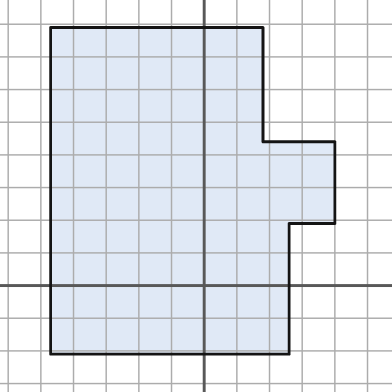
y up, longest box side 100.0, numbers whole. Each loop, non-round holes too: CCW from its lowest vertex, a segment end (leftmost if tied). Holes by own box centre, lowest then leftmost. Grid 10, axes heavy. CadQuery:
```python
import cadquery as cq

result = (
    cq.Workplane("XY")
    .moveTo(-47.0, -21.0)
    .lineTo(26.0, -21.0)
    .lineTo(26.0, 19.0)
    .lineTo(40.0, 19.0)
    .lineTo(40.0, 44.0)
    .lineTo(18.0, 44.0)
    .lineTo(18.0, 79.0)
    .lineTo(-47.0, 79.0)
    .close()
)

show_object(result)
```